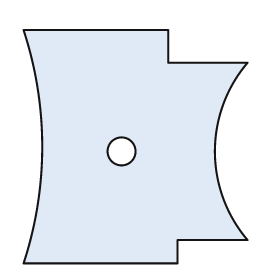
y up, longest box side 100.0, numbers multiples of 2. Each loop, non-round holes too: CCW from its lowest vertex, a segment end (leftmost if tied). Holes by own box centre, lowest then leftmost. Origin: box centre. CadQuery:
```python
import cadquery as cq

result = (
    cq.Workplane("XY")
    .moveTo(-48.0, -50.0)
    .lineTo(18.0, -50.0)
    .lineTo(18.0, -40.0)
    .lineTo(48.0, -40.0)
    .threePointArc((34.0, -2.0), (48.0, 36.0))
    .lineTo(14.0, 36.0)
    .lineTo(14.0, 50.0)
    .lineTo(-48.0, 50.0)
    .threePointArc((-40.0, 0.0), (-48.0, -50.0))
    .close()
    .moveTo(-6.0, -2.0)
    .circle(6.0)
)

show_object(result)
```